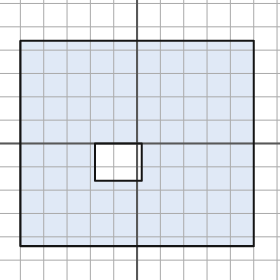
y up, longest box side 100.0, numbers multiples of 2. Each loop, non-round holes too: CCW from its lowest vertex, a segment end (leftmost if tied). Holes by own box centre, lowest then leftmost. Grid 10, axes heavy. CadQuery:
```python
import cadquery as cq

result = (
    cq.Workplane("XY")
    .moveTo(-50.0, -44.0)
    .lineTo(50.0, -44.0)
    .lineTo(50.0, 44.0)
    .lineTo(-50.0, 44.0)
    .close()
    .moveTo(-18.0, -16.0)
    .lineTo(2.0, -16.0)
    .lineTo(2.0, 0.0)
    .lineTo(-18.0, 0.0)
    .close()
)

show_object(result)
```